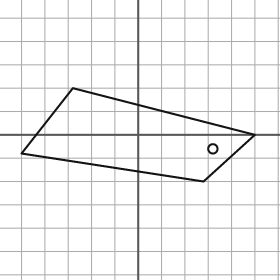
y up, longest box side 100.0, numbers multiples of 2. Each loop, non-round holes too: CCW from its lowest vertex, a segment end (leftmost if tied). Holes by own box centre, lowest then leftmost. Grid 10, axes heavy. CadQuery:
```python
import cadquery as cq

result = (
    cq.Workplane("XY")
    .moveTo(28.0, -20.0)
    .lineTo(50.0, 0.0)
    .lineTo(-28.0, 20.0)
    .lineTo(-50.0, -8.0)
    .close()
    .moveTo(32.0, -6.0)
    .circle(2.0)
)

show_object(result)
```